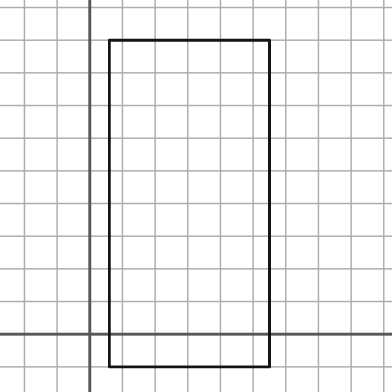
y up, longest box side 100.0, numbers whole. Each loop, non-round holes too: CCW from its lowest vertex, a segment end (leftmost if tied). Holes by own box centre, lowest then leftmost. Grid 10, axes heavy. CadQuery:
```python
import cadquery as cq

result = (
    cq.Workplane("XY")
    .moveTo(6.0, -10.0)
    .lineTo(55.0, -10.0)
    .lineTo(55.0, 90.0)
    .lineTo(6.0, 90.0)
    .close()
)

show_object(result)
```